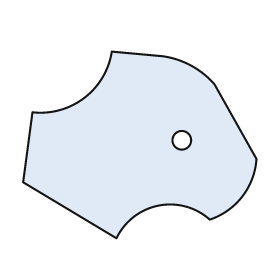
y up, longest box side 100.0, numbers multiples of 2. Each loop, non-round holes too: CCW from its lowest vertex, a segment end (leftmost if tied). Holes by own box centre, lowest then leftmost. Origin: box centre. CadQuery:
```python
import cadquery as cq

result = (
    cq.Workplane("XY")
    .moveTo(-10.0, -40.0)
    .threePointArc((8.0, -26.0), (30.0, -32.0))
    .threePointArc((44.0, -22.0), (50.0, -6.0))
    .lineTo(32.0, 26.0)
    .threePointArc((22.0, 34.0), (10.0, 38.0))
    .lineTo(-12.0, 40.0)
    .threePointArc((-24.0, 20.0), (-46.0, 14.0))
    .lineTo(-50.0, -16.0)
    .close()
    .moveTo(18.0, 2.0)
    .circle(4.0)
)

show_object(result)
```